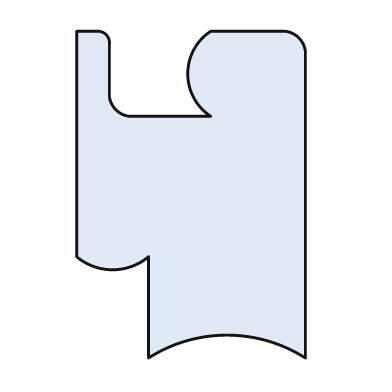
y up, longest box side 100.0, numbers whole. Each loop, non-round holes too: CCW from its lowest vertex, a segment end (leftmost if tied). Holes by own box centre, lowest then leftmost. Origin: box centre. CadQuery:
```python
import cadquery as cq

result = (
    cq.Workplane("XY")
    .moveTo(-13.0, -50.0)
    .threePointArc((11.0, -43.0), (35.0, -50.0))
    .lineTo(35.0, 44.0)
    .threePointArc((33.0, 48.0), (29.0, 50.0))
    .lineTo(6.0, 50.0)
    .threePointArc((-1.0, 37.0), (6.0, 24.0))
    .lineTo(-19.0, 24.0)
    .threePointArc((-23.0, 26.0), (-25.0, 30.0))
    .lineTo(-25.0, 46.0)
    .threePointArc((-26.0, 49.0), (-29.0, 50.0))
    .lineTo(-35.0, 50.0)
    .lineTo(-35.0, -19.0)
    .threePointArc((-24.0, -23.0), (-13.0, -19.0))
    .close()
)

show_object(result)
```